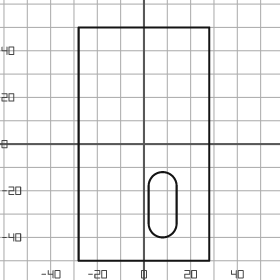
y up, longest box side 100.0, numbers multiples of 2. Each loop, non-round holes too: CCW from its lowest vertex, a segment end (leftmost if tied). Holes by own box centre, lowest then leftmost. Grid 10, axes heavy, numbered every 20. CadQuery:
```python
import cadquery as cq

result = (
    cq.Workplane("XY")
    .moveTo(-28.0, -50.0)
    .lineTo(28.0, -50.0)
    .lineTo(28.0, 50.0)
    .lineTo(-28.0, 50.0)
    .close()
    .moveTo(2.0, -34.0)
    .threePointArc((8.0, -40.0), (14.0, -34.0))
    .lineTo(14.0, -18.0)
    .threePointArc((8.0, -12.0), (2.0, -18.0))
    .close()
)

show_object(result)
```